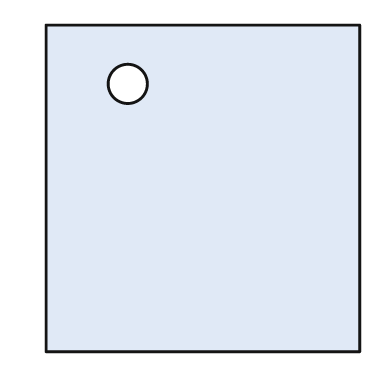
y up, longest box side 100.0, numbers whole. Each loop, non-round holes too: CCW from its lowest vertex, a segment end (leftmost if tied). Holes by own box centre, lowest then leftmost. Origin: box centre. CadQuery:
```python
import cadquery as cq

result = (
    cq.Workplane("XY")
    .moveTo(-48.0, -50.0)
    .lineTo(48.0, -50.0)
    .lineTo(48.0, 50.0)
    .lineTo(-48.0, 50.0)
    .close()
    .moveTo(-23.0, 32.0)
    .circle(6.0)
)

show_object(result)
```